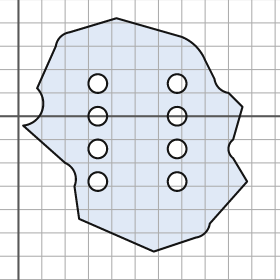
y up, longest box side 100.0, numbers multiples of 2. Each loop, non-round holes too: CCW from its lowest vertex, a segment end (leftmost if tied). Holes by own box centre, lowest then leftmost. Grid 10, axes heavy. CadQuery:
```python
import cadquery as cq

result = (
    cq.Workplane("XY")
    .moveTo(58.0, -58.0)
    .lineTo(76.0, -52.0)
    .threePointArc((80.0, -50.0), (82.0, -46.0))
    .lineTo(98.0, -28.0)
    .lineTo(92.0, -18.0)
    .threePointArc((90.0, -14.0), (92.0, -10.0))
    .lineTo(96.0, 4.0)
    .lineTo(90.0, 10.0)
    .threePointArc((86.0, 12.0), (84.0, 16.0))
    .lineTo(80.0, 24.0)
    .threePointArc((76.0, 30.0), (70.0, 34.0))
    .lineTo(42.0, 42.0)
    .lineTo(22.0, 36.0)
    .threePointArc((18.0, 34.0), (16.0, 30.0))
    .lineTo(8.0, 12.0)
    .threePointArc((10.0, 2.0), (2.0, -4.0))
    .lineTo(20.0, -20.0)
    .threePointArc((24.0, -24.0), (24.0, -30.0))
    .lineTo(26.0, -44.0)
    .close()
    .moveTo(34.0, -28.0)
    .circle(4.0)
    .moveTo(68.0, -28.0)
    .circle(4.0)
    .moveTo(34.0, -14.0)
    .circle(4.0)
    .moveTo(68.0, -14.0)
    .circle(4.0)
    .moveTo(34.0, 0.0)
    .circle(4.0)
    .moveTo(68.0, 0.0)
    .circle(4.0)
    .moveTo(34.0, 14.0)
    .circle(4.0)
    .moveTo(68.0, 14.0)
    .circle(4.0)
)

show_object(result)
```